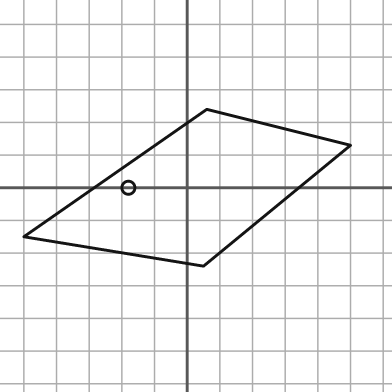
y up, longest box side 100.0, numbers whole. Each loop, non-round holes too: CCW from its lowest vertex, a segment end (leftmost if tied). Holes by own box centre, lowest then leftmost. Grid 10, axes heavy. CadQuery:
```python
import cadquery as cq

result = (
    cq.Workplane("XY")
    .moveTo(5.0, -24.0)
    .lineTo(50.0, 13.0)
    .lineTo(6.0, 24.0)
    .lineTo(-50.0, -15.0)
    .close()
    .moveTo(-18.0, 0.0)
    .circle(2.0)
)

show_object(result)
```